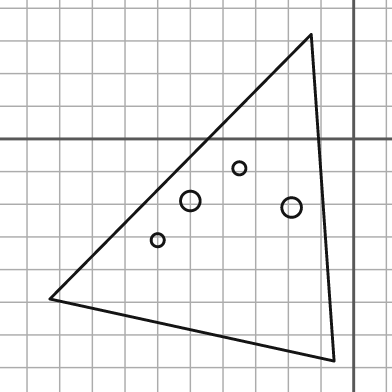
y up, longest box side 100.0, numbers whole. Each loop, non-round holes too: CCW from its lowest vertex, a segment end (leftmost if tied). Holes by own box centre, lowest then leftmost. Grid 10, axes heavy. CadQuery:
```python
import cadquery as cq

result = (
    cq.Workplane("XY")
    .moveTo(-6.0, -68.0)
    .lineTo(-13.0, 32.0)
    .lineTo(-93.0, -49.0)
    .close()
    .moveTo(-60.0, -31.0)
    .circle(2.0)
    .moveTo(-19.0, -21.0)
    .circle(3.0)
    .moveTo(-50.0, -19.0)
    .circle(3.0)
    .moveTo(-35.0, -9.0)
    .circle(2.0)
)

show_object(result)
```